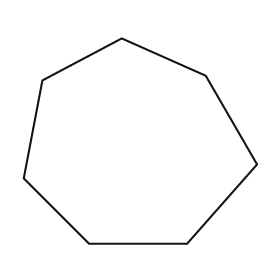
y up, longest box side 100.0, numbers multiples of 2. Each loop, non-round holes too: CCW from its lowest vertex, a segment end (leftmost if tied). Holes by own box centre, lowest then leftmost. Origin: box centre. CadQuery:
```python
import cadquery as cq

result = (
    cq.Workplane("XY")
    .moveTo(-22.0, -44.0)
    .lineTo(20.0, -44.0)
    .lineTo(50.0, -10.0)
    .lineTo(28.0, 28.0)
    .lineTo(-8.0, 44.0)
    .lineTo(-42.0, 26.0)
    .lineTo(-50.0, -16.0)
    .close()
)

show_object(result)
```